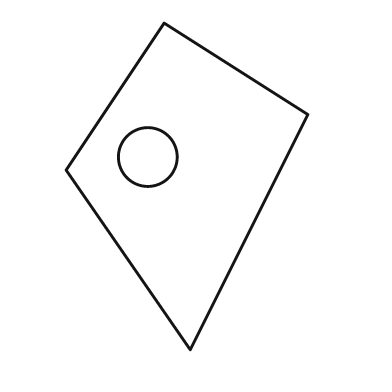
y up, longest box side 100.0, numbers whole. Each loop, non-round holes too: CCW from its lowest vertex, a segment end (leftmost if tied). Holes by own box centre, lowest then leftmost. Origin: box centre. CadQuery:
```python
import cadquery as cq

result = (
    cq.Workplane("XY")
    .moveTo(1.0, -50.0)
    .lineTo(37.0, 22.0)
    .lineTo(-7.0, 50.0)
    .lineTo(-37.0, 5.0)
    .close()
    .moveTo(-12.0, 9.0)
    .circle(9.0)
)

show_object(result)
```